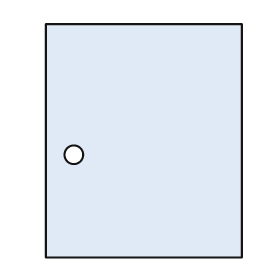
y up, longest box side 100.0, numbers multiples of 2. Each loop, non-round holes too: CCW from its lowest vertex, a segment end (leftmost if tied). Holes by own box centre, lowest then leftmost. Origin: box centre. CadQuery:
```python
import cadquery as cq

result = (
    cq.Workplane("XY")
    .moveTo(-42.0, -50.0)
    .lineTo(42.0, -50.0)
    .lineTo(42.0, 50.0)
    .lineTo(-42.0, 50.0)
    .close()
    .moveTo(-30.0, -6.0)
    .circle(4.0)
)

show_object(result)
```